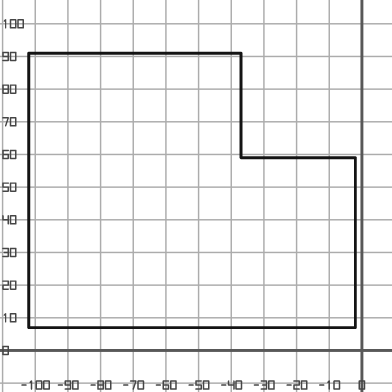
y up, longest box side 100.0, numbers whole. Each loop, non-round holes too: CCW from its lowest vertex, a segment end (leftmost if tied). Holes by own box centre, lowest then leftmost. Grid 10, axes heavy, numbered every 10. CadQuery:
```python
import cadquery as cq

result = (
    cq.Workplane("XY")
    .moveTo(-102.0, 7.0)
    .lineTo(-2.0, 7.0)
    .lineTo(-2.0, 59.0)
    .lineTo(-37.0, 59.0)
    .lineTo(-37.0, 91.0)
    .lineTo(-102.0, 91.0)
    .close()
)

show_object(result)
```